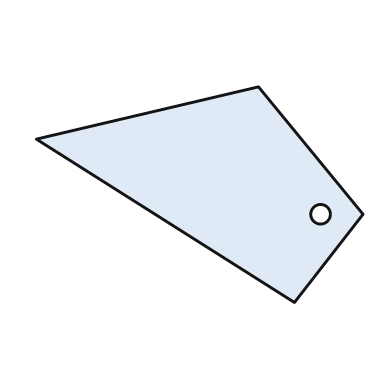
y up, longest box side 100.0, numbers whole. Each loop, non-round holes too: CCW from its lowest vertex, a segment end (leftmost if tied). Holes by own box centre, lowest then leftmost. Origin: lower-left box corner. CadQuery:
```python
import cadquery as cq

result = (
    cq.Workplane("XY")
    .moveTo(79.0, 0.0)
    .lineTo(100.0, 27.0)
    .lineTo(68.0, 66.0)
    .lineTo(0.0, 50.0)
    .close()
    .moveTo(87.0, 27.0)
    .circle(3.0)
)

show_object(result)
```